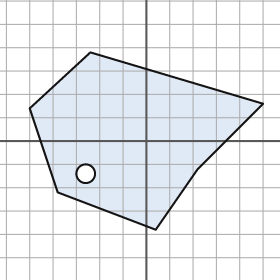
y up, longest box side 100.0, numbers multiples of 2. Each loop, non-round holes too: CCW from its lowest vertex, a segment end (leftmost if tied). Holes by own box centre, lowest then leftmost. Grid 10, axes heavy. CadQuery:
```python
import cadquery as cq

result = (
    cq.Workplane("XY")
    .moveTo(4.0, -38.0)
    .lineTo(22.0, -12.0)
    .lineTo(50.0, 16.0)
    .lineTo(-24.0, 38.0)
    .lineTo(-50.0, 14.0)
    .lineTo(-38.0, -22.0)
    .close()
    .moveTo(-26.0, -14.0)
    .circle(4.0)
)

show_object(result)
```